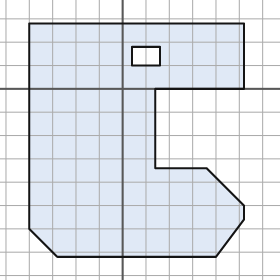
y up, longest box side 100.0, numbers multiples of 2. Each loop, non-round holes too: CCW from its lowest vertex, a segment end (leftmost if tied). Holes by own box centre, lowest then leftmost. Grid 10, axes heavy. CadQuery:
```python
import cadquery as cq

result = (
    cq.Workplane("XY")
    .moveTo(-28.0, -72.0)
    .lineTo(40.0, -72.0)
    .lineTo(52.0, -56.0)
    .lineTo(52.0, -50.0)
    .lineTo(36.0, -34.0)
    .lineTo(14.0, -34.0)
    .lineTo(14.0, 0.0)
    .lineTo(52.0, 0.0)
    .lineTo(52.0, 28.0)
    .lineTo(-40.0, 28.0)
    .lineTo(-40.0, -60.0)
    .close()
    .moveTo(4.0, 10.0)
    .lineTo(16.0, 10.0)
    .lineTo(16.0, 18.0)
    .lineTo(4.0, 18.0)
    .close()
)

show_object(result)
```